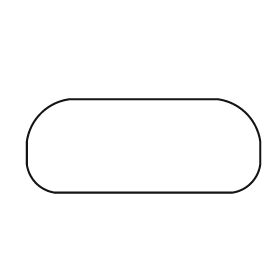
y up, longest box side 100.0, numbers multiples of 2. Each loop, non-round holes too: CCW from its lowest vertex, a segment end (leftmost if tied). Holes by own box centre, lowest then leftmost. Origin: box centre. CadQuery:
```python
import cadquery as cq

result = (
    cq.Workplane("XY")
    .moveTo(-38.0, -20.0)
    .lineTo(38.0, -20.0)
    .threePointArc((46.0, -16.0), (50.0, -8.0))
    .lineTo(50.0, 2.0)
    .threePointArc((44.0, 14.0), (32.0, 20.0))
    .lineTo(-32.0, 20.0)
    .threePointArc((-44.0, 14.0), (-50.0, 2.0))
    .lineTo(-50.0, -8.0)
    .threePointArc((-46.0, -16.0), (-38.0, -20.0))
    .close()
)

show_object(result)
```